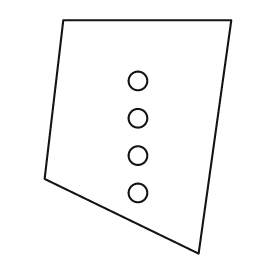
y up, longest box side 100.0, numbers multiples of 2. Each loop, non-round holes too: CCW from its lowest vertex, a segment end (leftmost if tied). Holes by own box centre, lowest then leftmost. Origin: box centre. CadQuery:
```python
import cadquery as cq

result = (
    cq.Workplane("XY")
    .moveTo(26.0, -50.0)
    .lineTo(40.0, 50.0)
    .lineTo(-32.0, 50.0)
    .lineTo(-40.0, -18.0)
    .close()
    .moveTo(0.0, -24.0)
    .circle(4.0)
    .moveTo(0.0, -8.0)
    .circle(4.0)
    .moveTo(0.0, 8.0)
    .circle(4.0)
    .moveTo(0.0, 24.0)
    .circle(4.0)
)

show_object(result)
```